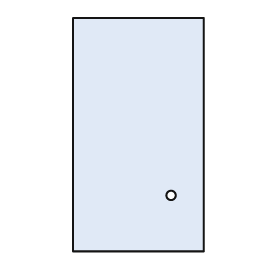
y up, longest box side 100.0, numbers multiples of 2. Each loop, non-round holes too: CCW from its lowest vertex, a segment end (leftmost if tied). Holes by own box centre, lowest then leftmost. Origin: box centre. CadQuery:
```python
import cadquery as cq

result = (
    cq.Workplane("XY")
    .moveTo(-28.0, -50.0)
    .lineTo(28.0, -50.0)
    .lineTo(28.0, 50.0)
    .lineTo(-28.0, 50.0)
    .close()
    .moveTo(14.0, -26.0)
    .circle(2.0)
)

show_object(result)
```